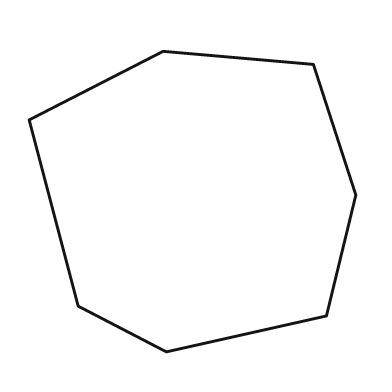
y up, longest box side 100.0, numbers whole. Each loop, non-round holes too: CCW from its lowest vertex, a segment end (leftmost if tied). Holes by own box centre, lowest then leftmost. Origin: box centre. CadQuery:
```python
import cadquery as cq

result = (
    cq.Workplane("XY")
    .moveTo(-8.0, -46.0)
    .lineTo(41.0, -35.0)
    .lineTo(50.0, 2.0)
    .lineTo(37.0, 42.0)
    .lineTo(-9.0, 46.0)
    .lineTo(-50.0, 25.0)
    .lineTo(-35.0, -32.0)
    .close()
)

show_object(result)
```